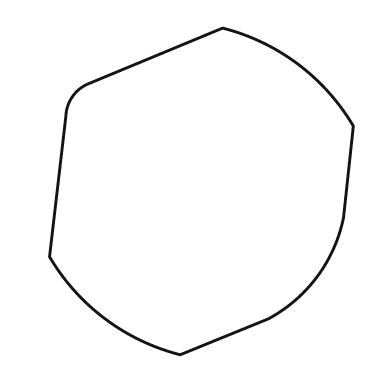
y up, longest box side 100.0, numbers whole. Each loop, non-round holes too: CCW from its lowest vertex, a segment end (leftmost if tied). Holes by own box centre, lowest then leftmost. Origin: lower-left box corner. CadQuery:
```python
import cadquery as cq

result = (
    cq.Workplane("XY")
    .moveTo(40.0, 0.0)
    .lineTo(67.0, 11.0)
    .threePointArc((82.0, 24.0), (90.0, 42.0))
    .lineTo(93.0, 70.0)
    .threePointArc((76.0, 89.0), (53.0, 100.0))
    .lineTo(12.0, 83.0)
    .threePointArc((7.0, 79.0), (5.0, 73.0))
    .lineTo(0.0, 30.0)
    .threePointArc((17.0, 11.0), (40.0, 0.0))
    .close()
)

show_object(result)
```